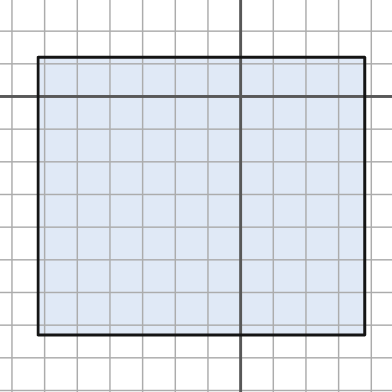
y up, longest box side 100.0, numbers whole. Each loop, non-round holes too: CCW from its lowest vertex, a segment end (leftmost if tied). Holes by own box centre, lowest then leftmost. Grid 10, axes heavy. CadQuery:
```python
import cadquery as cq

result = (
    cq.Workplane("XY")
    .moveTo(-62.0, -73.0)
    .lineTo(38.0, -73.0)
    .lineTo(38.0, 12.0)
    .lineTo(-62.0, 12.0)
    .close()
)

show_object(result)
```